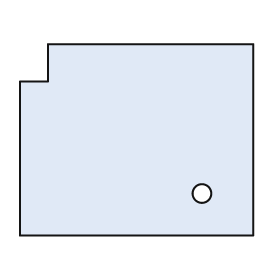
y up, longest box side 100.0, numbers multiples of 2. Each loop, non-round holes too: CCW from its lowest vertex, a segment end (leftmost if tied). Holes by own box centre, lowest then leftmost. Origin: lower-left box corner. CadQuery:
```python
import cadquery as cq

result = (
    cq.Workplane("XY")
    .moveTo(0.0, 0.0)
    .lineTo(100.0, 0.0)
    .lineTo(100.0, 82.0)
    .lineTo(12.0, 82.0)
    .lineTo(12.0, 66.0)
    .lineTo(0.0, 66.0)
    .close()
    .moveTo(78.0, 18.0)
    .circle(4.0)
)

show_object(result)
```